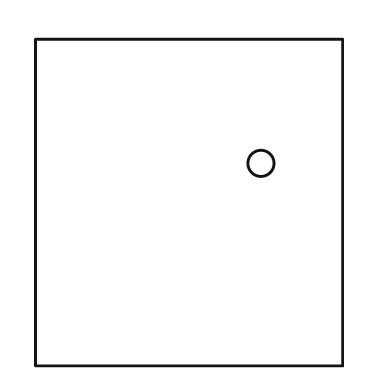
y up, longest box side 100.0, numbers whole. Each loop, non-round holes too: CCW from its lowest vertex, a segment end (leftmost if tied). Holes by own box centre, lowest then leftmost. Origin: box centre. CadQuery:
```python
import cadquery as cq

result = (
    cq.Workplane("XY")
    .moveTo(-47.0, -50.0)
    .lineTo(47.0, -50.0)
    .lineTo(47.0, 50.0)
    .lineTo(-47.0, 50.0)
    .close()
    .moveTo(22.0, 12.0)
    .circle(4.0)
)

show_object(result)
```